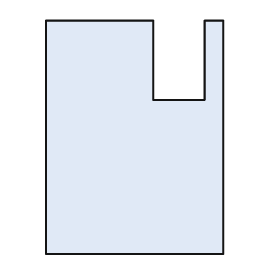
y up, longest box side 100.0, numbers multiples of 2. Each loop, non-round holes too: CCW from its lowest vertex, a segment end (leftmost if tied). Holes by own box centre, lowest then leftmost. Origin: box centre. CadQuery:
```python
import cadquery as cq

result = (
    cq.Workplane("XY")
    .moveTo(-38.0, -50.0)
    .lineTo(38.0, -50.0)
    .lineTo(38.0, 50.0)
    .lineTo(30.0, 50.0)
    .lineTo(30.0, 16.0)
    .lineTo(8.0, 16.0)
    .lineTo(8.0, 50.0)
    .lineTo(-38.0, 50.0)
    .close()
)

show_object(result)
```